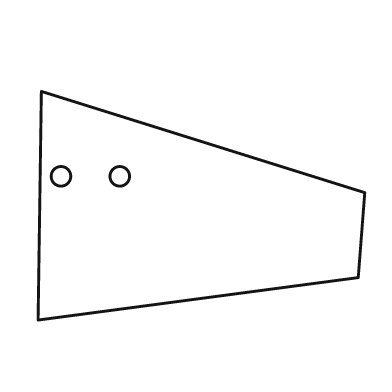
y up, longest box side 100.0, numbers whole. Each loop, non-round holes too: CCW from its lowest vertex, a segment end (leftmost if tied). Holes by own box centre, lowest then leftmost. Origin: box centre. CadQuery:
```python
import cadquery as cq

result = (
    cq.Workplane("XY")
    .moveTo(-50.0, -35.0)
    .lineTo(48.0, -22.0)
    .lineTo(50.0, 4.0)
    .lineTo(-49.0, 35.0)
    .close()
    .moveTo(-43.0, 9.0)
    .circle(3.0)
    .moveTo(-25.0, 9.0)
    .circle(3.0)
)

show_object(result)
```